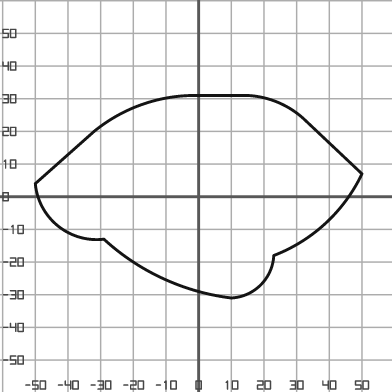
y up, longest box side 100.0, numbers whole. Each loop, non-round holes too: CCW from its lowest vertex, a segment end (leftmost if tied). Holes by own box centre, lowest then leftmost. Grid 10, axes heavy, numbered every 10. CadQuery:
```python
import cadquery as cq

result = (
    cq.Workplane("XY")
    .moveTo(10.0, -31.0)
    .threePointArc((19.0, -27.0), (23.0, -18.0))
    .threePointArc((39.0, -8.0), (50.0, 7.0))
    .lineTo(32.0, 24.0)
    .threePointArc((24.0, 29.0), (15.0, 31.0))
    .lineTo(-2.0, 31.0)
    .threePointArc((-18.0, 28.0), (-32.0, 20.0))
    .lineTo(-50.0, 4.0)
    .threePointArc((-43.0, -9.0), (-29.0, -13.0))
    .threePointArc((-11.0, -25.0), (10.0, -31.0))
    .close()
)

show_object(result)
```